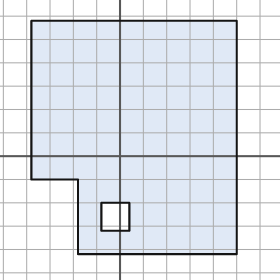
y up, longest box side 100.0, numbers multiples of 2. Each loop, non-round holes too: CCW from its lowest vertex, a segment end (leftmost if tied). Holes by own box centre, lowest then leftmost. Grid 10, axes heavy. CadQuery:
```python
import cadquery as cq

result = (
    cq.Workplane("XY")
    .moveTo(-18.0, -42.0)
    .lineTo(50.0, -42.0)
    .lineTo(50.0, 58.0)
    .lineTo(-38.0, 58.0)
    .lineTo(-38.0, -10.0)
    .lineTo(-18.0, -10.0)
    .close()
    .moveTo(-8.0, -32.0)
    .lineTo(4.0, -32.0)
    .lineTo(4.0, -20.0)
    .lineTo(-8.0, -20.0)
    .close()
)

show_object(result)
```